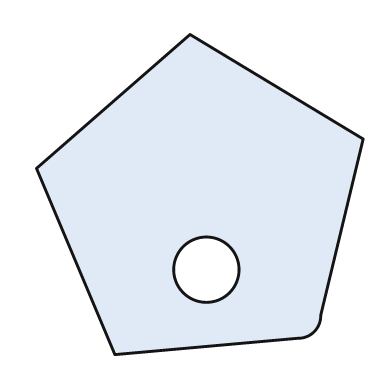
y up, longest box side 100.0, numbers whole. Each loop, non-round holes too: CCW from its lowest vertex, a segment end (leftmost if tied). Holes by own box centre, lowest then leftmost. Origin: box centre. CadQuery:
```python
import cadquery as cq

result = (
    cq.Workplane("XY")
    .moveTo(-26.0, -49.0)
    .lineTo(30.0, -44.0)
    .threePointArc((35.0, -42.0), (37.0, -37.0))
    .lineTo(50.0, 17.0)
    .lineTo(-3.0, 49.0)
    .lineTo(-50.0, 8.0)
    .close()
    .moveTo(2.0, -23.0)
    .circle(10.0)
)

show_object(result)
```